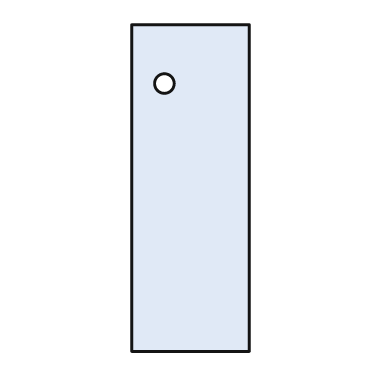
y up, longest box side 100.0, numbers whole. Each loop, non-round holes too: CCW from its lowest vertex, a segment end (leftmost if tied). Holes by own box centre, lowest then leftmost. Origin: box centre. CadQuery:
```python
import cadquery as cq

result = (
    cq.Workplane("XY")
    .moveTo(-18.0, -50.0)
    .lineTo(18.0, -50.0)
    .lineTo(18.0, 50.0)
    .lineTo(-18.0, 50.0)
    .close()
    .moveTo(-8.0, 32.0)
    .circle(3.0)
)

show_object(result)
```